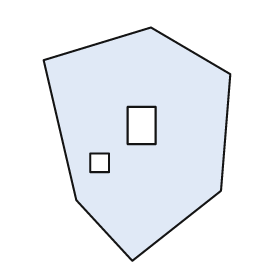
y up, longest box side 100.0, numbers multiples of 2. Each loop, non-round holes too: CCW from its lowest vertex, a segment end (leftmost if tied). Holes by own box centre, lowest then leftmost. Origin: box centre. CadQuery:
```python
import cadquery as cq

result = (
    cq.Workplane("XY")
    .moveTo(-2.0, -50.0)
    .lineTo(36.0, -20.0)
    .lineTo(40.0, 30.0)
    .lineTo(6.0, 50.0)
    .lineTo(-40.0, 36.0)
    .lineTo(-26.0, -24.0)
    .close()
    .moveTo(-20.0, -12.0)
    .lineTo(-12.0, -12.0)
    .lineTo(-12.0, -4.0)
    .lineTo(-20.0, -4.0)
    .close()
    .moveTo(-4.0, 0.0)
    .lineTo(8.0, 0.0)
    .lineTo(8.0, 16.0)
    .lineTo(-4.0, 16.0)
    .close()
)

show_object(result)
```